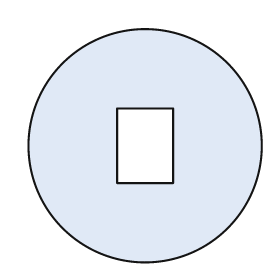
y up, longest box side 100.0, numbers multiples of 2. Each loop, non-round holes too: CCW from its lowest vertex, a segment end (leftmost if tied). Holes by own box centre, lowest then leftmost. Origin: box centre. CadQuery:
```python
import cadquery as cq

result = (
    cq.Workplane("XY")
    .moveTo(0.0, 0.0)
    .circle(50.0)
    .moveTo(-12.0, -16.0)
    .lineTo(12.0, -16.0)
    .lineTo(12.0, 16.0)
    .lineTo(-12.0, 16.0)
    .close()
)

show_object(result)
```